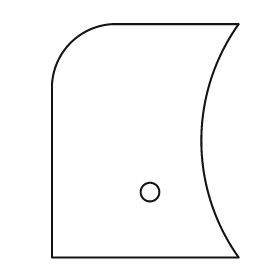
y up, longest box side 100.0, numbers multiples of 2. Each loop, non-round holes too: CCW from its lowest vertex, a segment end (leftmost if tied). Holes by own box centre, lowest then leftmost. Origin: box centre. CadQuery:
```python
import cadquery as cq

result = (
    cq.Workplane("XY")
    .moveTo(-40.0, -50.0)
    .lineTo(40.0, -50.0)
    .threePointArc((24.0, 0.0), (40.0, 50.0))
    .lineTo(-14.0, 50.0)
    .threePointArc((-32.0, 42.0), (-40.0, 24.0))
    .close()
    .moveTo(2.0, -22.0)
    .circle(4.0)
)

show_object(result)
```